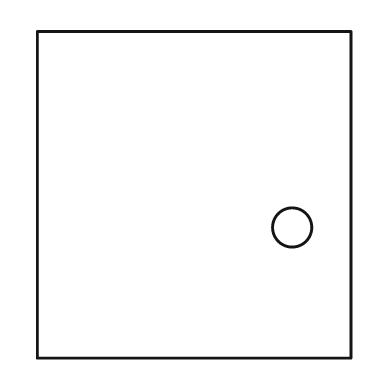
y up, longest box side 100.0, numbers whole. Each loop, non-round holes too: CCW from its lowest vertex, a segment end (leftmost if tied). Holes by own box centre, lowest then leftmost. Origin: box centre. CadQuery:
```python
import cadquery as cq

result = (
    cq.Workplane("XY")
    .moveTo(-48.0, -50.0)
    .lineTo(48.0, -50.0)
    .lineTo(48.0, 50.0)
    .lineTo(-48.0, 50.0)
    .close()
    .moveTo(30.0, -10.0)
    .circle(6.0)
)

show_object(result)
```